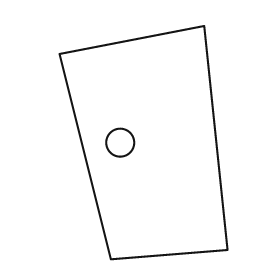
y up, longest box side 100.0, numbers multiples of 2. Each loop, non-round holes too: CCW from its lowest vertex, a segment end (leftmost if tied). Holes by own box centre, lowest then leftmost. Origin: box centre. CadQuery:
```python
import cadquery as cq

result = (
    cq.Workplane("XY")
    .moveTo(-14.0, -50.0)
    .lineTo(36.0, -46.0)
    .lineTo(26.0, 50.0)
    .lineTo(-36.0, 38.0)
    .close()
    .moveTo(-10.0, 0.0)
    .circle(6.0)
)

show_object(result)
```